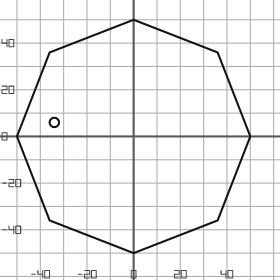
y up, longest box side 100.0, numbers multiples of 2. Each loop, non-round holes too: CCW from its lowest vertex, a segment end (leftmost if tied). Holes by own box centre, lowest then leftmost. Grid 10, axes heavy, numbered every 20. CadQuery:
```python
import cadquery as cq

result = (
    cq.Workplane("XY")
    .moveTo(0.0, -50.0)
    .lineTo(36.0, -36.0)
    .lineTo(50.0, 0.0)
    .lineTo(36.0, 36.0)
    .lineTo(0.0, 50.0)
    .lineTo(-36.0, 36.0)
    .lineTo(-50.0, 0.0)
    .lineTo(-36.0, -36.0)
    .close()
    .moveTo(-34.0, 6.0)
    .circle(2.0)
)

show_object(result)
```